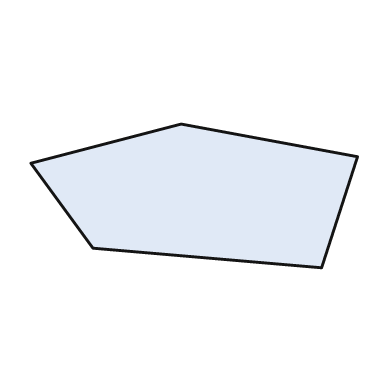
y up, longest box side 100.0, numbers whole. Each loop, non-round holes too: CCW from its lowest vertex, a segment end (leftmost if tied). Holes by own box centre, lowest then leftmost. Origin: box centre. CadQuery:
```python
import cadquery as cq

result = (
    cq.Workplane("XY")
    .moveTo(39.0, -22.0)
    .lineTo(50.0, 12.0)
    .lineTo(-4.0, 22.0)
    .lineTo(-50.0, 10.0)
    .lineTo(-31.0, -16.0)
    .close()
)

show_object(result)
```